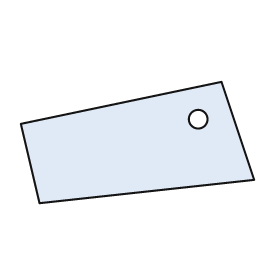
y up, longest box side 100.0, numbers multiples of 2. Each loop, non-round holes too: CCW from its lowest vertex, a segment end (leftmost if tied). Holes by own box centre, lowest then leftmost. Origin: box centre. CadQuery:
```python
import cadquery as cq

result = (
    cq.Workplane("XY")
    .moveTo(-42.0, -26.0)
    .lineTo(50.0, -16.0)
    .lineTo(36.0, 26.0)
    .lineTo(-50.0, 8.0)
    .close()
    .moveTo(26.0, 10.0)
    .circle(4.0)
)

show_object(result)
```